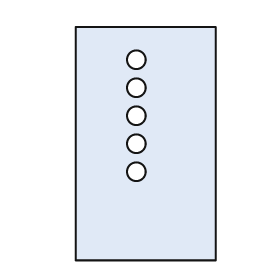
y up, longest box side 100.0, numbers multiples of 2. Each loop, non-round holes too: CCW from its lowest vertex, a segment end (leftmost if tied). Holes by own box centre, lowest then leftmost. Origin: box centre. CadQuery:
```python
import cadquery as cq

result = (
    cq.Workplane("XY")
    .moveTo(-30.0, -50.0)
    .lineTo(30.0, -50.0)
    .lineTo(30.0, 50.0)
    .lineTo(-30.0, 50.0)
    .close()
    .moveTo(-4.0, -12.0)
    .circle(4.0)
    .moveTo(-4.0, 0.0)
    .circle(4.0)
    .moveTo(-4.0, 12.0)
    .circle(4.0)
    .moveTo(-4.0, 24.0)
    .circle(4.0)
    .moveTo(-4.0, 36.0)
    .circle(4.0)
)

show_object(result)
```